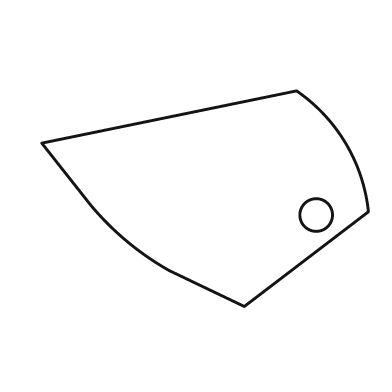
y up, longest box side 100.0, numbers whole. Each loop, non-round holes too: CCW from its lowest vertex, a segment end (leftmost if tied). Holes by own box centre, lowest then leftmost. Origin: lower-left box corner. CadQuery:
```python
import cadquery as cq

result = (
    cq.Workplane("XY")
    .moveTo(62.0, 0.0)
    .lineTo(100.0, 29.0)
    .threePointArc((93.0, 50.0), (78.0, 66.0))
    .lineTo(0.0, 50.0)
    .lineTo(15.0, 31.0)
    .threePointArc((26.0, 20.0), (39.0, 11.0))
    .close()
    .moveTo(84.0, 28.0)
    .circle(5.0)
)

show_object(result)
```